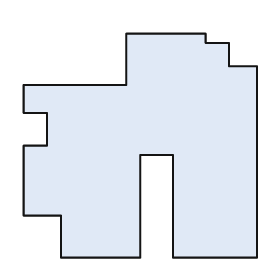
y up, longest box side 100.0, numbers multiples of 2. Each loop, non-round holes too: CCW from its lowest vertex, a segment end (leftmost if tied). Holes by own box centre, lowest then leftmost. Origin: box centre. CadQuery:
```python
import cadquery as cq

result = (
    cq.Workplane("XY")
    .moveTo(-34.0, -48.0)
    .lineTo(0.0, -48.0)
    .lineTo(0.0, -4.0)
    .lineTo(14.0, -4.0)
    .lineTo(14.0, -48.0)
    .lineTo(50.0, -48.0)
    .lineTo(50.0, 34.0)
    .lineTo(38.0, 34.0)
    .lineTo(38.0, 44.0)
    .lineTo(28.0, 44.0)
    .lineTo(28.0, 48.0)
    .lineTo(-6.0, 48.0)
    .lineTo(-6.0, 26.0)
    .lineTo(-50.0, 26.0)
    .lineTo(-50.0, 14.0)
    .lineTo(-40.0, 14.0)
    .lineTo(-40.0, 0.0)
    .lineTo(-50.0, 0.0)
    .lineTo(-50.0, -30.0)
    .lineTo(-34.0, -30.0)
    .close()
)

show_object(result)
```